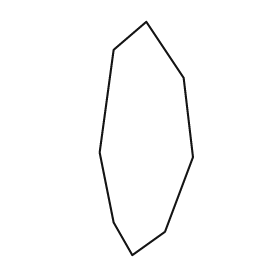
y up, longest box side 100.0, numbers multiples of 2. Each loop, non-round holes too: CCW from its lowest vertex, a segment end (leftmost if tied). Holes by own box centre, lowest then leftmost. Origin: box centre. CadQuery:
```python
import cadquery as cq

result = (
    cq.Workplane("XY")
    .moveTo(-6.0, -50.0)
    .lineTo(8.0, -40.0)
    .lineTo(20.0, -8.0)
    .lineTo(16.0, 26.0)
    .lineTo(0.0, 50.0)
    .lineTo(-14.0, 38.0)
    .lineTo(-20.0, -6.0)
    .lineTo(-14.0, -36.0)
    .close()
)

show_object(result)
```